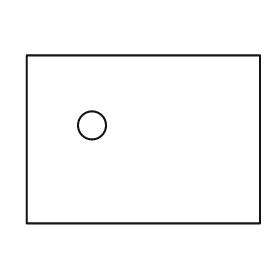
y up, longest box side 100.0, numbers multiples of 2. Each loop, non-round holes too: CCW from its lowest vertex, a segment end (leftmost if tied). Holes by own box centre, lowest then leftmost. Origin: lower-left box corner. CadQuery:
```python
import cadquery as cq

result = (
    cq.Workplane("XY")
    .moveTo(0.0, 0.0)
    .lineTo(100.0, 0.0)
    .lineTo(100.0, 72.0)
    .lineTo(0.0, 72.0)
    .close()
    .moveTo(28.0, 42.0)
    .circle(6.0)
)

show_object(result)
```